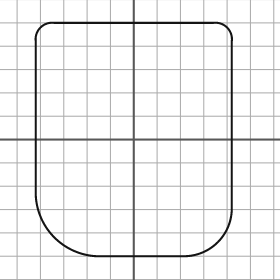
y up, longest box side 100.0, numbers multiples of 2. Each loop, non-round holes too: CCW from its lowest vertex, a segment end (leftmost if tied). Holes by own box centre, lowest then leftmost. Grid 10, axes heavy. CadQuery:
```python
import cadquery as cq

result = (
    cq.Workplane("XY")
    .moveTo(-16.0, -50.0)
    .lineTo(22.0, -50.0)
    .threePointArc((36.0, -44.0), (42.0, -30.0))
    .lineTo(42.0, 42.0)
    .threePointArc((40.0, 48.0), (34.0, 50.0))
    .lineTo(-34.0, 50.0)
    .threePointArc((-40.0, 48.0), (-42.0, 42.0))
    .lineTo(-42.0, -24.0)
    .threePointArc((-34.0, -42.0), (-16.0, -50.0))
    .close()
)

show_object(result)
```